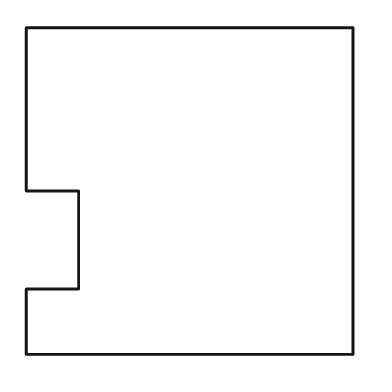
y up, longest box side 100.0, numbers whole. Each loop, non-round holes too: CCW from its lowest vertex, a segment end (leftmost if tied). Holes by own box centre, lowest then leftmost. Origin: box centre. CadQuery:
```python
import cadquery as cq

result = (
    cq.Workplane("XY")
    .moveTo(-50.0, -50.0)
    .lineTo(50.0, -50.0)
    .lineTo(50.0, 50.0)
    .lineTo(-50.0, 50.0)
    .lineTo(-50.0, 0.0)
    .lineTo(-34.0, 0.0)
    .lineTo(-34.0, -30.0)
    .lineTo(-50.0, -30.0)
    .close()
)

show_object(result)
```